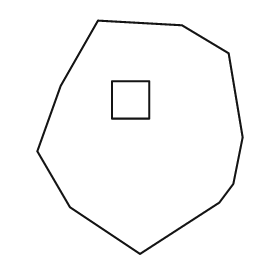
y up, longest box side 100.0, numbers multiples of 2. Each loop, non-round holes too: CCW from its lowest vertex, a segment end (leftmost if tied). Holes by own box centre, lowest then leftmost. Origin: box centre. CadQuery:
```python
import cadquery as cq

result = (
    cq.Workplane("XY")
    .moveTo(0.0, -50.0)
    .lineTo(34.0, -28.0)
    .lineTo(40.0, -20.0)
    .lineTo(44.0, 0.0)
    .lineTo(38.0, 36.0)
    .lineTo(18.0, 48.0)
    .lineTo(-18.0, 50.0)
    .lineTo(-34.0, 22.0)
    .lineTo(-44.0, -6.0)
    .lineTo(-30.0, -30.0)
    .close()
    .moveTo(-12.0, 8.0)
    .lineTo(4.0, 8.0)
    .lineTo(4.0, 24.0)
    .lineTo(-12.0, 24.0)
    .close()
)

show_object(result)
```